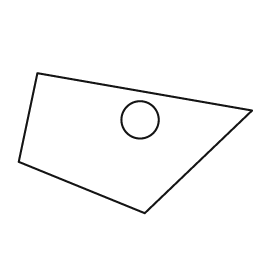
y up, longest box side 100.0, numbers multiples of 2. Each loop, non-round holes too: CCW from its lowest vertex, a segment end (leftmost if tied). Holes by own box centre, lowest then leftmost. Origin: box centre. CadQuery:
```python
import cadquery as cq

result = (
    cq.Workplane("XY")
    .moveTo(4.0, -30.0)
    .lineTo(50.0, 14.0)
    .lineTo(-42.0, 30.0)
    .lineTo(-50.0, -8.0)
    .close()
    .moveTo(2.0, 10.0)
    .circle(8.0)
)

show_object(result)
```